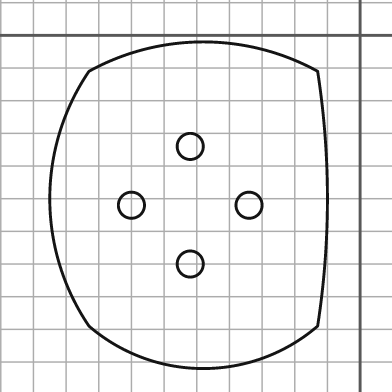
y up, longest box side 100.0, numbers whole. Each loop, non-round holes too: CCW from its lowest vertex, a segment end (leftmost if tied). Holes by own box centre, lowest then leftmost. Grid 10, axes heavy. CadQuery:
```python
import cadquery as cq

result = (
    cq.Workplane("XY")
    .moveTo(-83.0, -89.0)
    .threePointArc((-48.0, -102.0), (-13.0, -89.0))
    .threePointArc((-10.0, -50.0), (-13.0, -11.0))
    .threePointArc((-48.0, -2.0), (-83.0, -11.0))
    .threePointArc((-95.0, -50.0), (-83.0, -89.0))
    .close()
    .moveTo(-52.0, -70.0)
    .circle(4.0)
    .moveTo(-70.0, -52.0)
    .circle(4.0)
    .moveTo(-34.0, -52.0)
    .circle(4.0)
    .moveTo(-52.0, -34.0)
    .circle(4.0)
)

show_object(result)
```